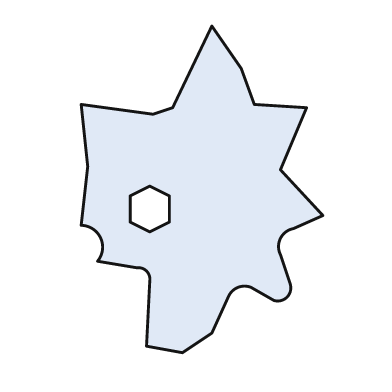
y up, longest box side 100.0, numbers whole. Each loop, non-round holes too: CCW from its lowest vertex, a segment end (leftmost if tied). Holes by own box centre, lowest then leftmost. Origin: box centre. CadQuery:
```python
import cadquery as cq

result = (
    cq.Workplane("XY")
    .moveTo(-6.0, -50.0)
    .lineTo(3.0, -44.0)
    .lineTo(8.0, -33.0)
    .threePointArc((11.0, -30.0), (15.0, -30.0))
    .lineTo(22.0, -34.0)
    .threePointArc((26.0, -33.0), (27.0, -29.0))
    .lineTo(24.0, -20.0)
    .threePointArc((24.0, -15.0), (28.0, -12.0))
    .lineTo(37.0, -8.0)
    .lineTo(24.0, 6.0)
    .lineTo(32.0, 25.0)
    .lineTo(16.0, 26.0)
    .lineTo(12.0, 37.0)
    .lineTo(3.0, 50.0)
    .lineTo(-9.0, 25.0)
    .lineTo(-15.0, 23.0)
    .lineTo(-37.0, 26.0)
    .lineTo(-35.0, 7.0)
    .lineTo(-37.0, -11.0)
    .threePointArc((-31.0, -15.0), (-32.0, -22.0))
    .lineTo(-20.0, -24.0)
    .threePointArc((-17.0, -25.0), (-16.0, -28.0))
    .lineTo(-17.0, -48.0)
    .close()
    .moveTo(-16.0, -13.0)
    .lineTo(-10.0, -10.0)
    .lineTo(-10.0, -2.0)
    .lineTo(-16.0, 1.0)
    .lineTo(-22.0, -2.0)
    .lineTo(-22.0, -10.0)
    .close()
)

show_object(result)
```